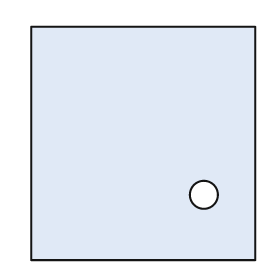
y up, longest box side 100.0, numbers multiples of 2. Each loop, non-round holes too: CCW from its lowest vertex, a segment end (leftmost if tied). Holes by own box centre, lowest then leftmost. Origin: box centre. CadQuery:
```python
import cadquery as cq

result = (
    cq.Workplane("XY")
    .moveTo(-48.0, -50.0)
    .lineTo(48.0, -50.0)
    .lineTo(48.0, 50.0)
    .lineTo(-48.0, 50.0)
    .close()
    .moveTo(26.0, -22.0)
    .circle(6.0)
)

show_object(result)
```